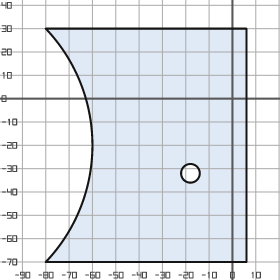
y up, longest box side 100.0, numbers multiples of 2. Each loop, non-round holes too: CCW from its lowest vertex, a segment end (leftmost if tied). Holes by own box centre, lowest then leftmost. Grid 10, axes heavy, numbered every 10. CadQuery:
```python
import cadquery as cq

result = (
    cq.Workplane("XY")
    .moveTo(-80.0, -70.0)
    .lineTo(6.0, -70.0)
    .lineTo(6.0, 30.0)
    .lineTo(-80.0, 30.0)
    .threePointArc((-60.0, -20.0), (-80.0, -70.0))
    .close()
    .moveTo(-18.0, -32.0)
    .circle(4.0)
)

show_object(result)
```